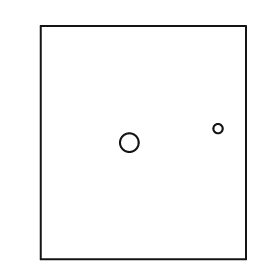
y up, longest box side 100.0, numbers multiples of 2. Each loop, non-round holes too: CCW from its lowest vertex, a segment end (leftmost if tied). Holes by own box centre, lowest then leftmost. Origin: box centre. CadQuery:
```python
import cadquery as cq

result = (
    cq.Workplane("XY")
    .moveTo(-44.0, -50.0)
    .lineTo(44.0, -50.0)
    .lineTo(44.0, 50.0)
    .lineTo(-44.0, 50.0)
    .close()
    .moveTo(-6.0, 0.0)
    .circle(4.0)
    .moveTo(32.0, 6.0)
    .circle(2.0)
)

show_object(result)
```